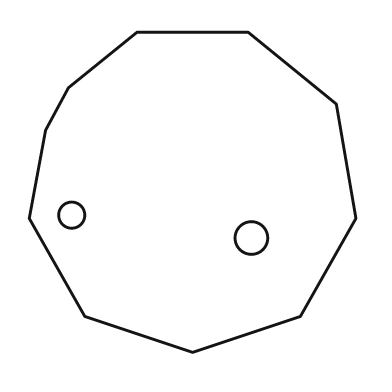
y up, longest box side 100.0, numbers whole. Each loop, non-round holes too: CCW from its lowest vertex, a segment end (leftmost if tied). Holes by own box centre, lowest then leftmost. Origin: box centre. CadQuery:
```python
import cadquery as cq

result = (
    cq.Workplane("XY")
    .moveTo(0.0, -49.0)
    .lineTo(33.0, -38.0)
    .lineTo(50.0, -8.0)
    .lineTo(44.0, 27.0)
    .lineTo(17.0, 49.0)
    .lineTo(-17.0, 49.0)
    .lineTo(-38.0, 32.0)
    .lineTo(-45.0, 19.0)
    .lineTo(-50.0, -8.0)
    .lineTo(-33.0, -38.0)
    .close()
    .moveTo(18.0, -14.0)
    .circle(5.0)
    .moveTo(-37.0, -7.0)
    .circle(4.0)
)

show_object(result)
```